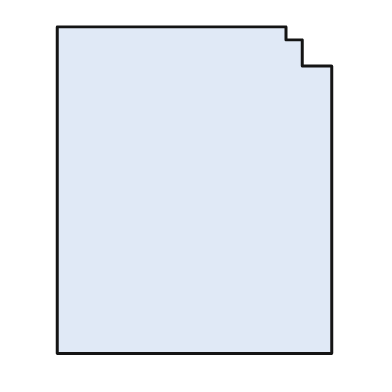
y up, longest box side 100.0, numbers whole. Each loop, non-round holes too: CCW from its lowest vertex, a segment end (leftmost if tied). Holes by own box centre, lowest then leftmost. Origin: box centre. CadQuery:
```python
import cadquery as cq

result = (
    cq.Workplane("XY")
    .moveTo(-42.0, -50.0)
    .lineTo(42.0, -50.0)
    .lineTo(42.0, 38.0)
    .lineTo(33.0, 38.0)
    .lineTo(33.0, 46.0)
    .lineTo(28.0, 46.0)
    .lineTo(28.0, 50.0)
    .lineTo(-42.0, 50.0)
    .close()
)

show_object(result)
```